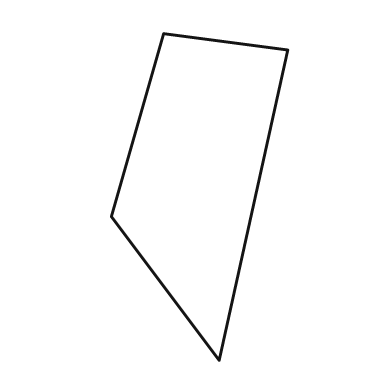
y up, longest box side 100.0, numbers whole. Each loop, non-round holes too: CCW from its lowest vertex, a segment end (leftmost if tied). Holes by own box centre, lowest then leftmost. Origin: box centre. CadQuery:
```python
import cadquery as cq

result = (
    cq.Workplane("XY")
    .moveTo(6.0, -50.0)
    .lineTo(27.0, 45.0)
    .lineTo(-11.0, 50.0)
    .lineTo(-27.0, -6.0)
    .close()
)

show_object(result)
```